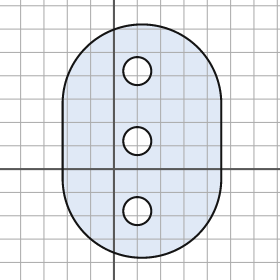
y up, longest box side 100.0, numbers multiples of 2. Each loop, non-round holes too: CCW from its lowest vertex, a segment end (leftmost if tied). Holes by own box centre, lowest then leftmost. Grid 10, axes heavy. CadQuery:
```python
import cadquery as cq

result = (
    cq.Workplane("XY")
    .moveTo(-22.0, -4.0)
    .threePointArc((12.0, -38.0), (46.0, -4.0))
    .lineTo(46.0, 28.0)
    .threePointArc((12.0, 62.0), (-22.0, 28.0))
    .close()
    .moveTo(10.0, -18.0)
    .circle(6.0)
    .moveTo(10.0, 12.0)
    .circle(6.0)
    .moveTo(10.0, 42.0)
    .circle(6.0)
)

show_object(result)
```